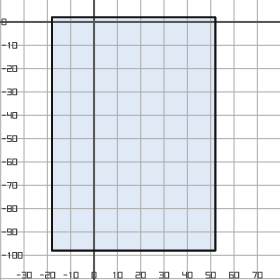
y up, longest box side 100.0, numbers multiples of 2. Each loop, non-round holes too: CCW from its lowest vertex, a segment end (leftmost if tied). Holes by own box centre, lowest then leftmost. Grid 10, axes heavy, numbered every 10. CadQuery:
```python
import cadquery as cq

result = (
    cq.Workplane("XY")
    .moveTo(-18.0, -98.0)
    .lineTo(52.0, -98.0)
    .lineTo(52.0, 2.0)
    .lineTo(-18.0, 2.0)
    .close()
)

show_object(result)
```